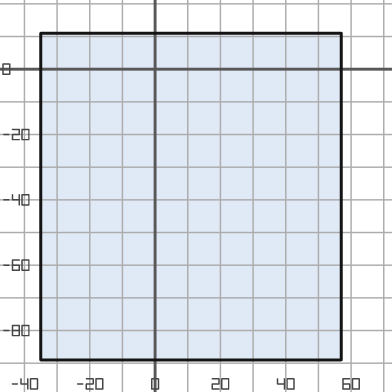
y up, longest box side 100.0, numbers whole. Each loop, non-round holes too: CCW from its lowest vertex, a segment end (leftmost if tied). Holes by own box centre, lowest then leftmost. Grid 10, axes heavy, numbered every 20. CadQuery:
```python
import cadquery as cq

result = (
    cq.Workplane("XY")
    .moveTo(-35.0, -89.0)
    .lineTo(57.0, -89.0)
    .lineTo(57.0, 11.0)
    .lineTo(-35.0, 11.0)
    .close()
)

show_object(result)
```